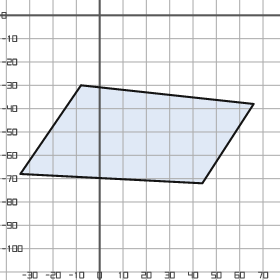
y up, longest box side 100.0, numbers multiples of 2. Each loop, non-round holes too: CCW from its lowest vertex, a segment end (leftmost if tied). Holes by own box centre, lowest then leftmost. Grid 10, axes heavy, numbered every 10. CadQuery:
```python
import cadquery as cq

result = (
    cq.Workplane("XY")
    .moveTo(44.0, -72.0)
    .lineTo(66.0, -38.0)
    .lineTo(-8.0, -30.0)
    .lineTo(-34.0, -68.0)
    .close()
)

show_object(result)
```